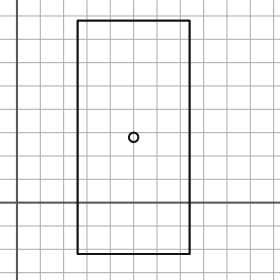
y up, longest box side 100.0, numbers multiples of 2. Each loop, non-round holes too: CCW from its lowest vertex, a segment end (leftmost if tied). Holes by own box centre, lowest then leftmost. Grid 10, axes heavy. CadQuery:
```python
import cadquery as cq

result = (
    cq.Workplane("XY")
    .moveTo(26.0, -22.0)
    .lineTo(74.0, -22.0)
    .lineTo(74.0, 78.0)
    .lineTo(26.0, 78.0)
    .close()
    .moveTo(50.0, 28.0)
    .circle(2.0)
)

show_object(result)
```